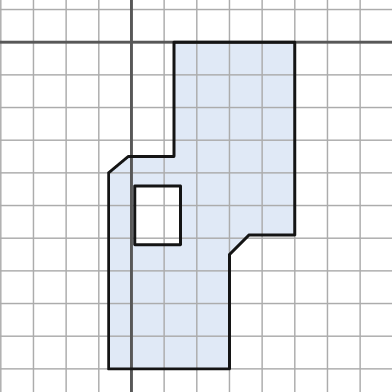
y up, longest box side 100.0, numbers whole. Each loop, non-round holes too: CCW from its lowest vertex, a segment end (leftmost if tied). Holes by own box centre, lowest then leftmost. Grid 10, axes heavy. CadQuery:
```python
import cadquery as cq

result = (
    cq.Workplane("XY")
    .moveTo(-7.0, -100.0)
    .lineTo(30.0, -100.0)
    .lineTo(30.0, -65.0)
    .lineTo(36.0, -59.0)
    .lineTo(50.0, -59.0)
    .lineTo(50.0, 0.0)
    .lineTo(13.0, 0.0)
    .lineTo(13.0, -35.0)
    .lineTo(-1.0, -35.0)
    .lineTo(-7.0, -40.0)
    .close()
    .moveTo(1.0, -62.0)
    .lineTo(15.0, -62.0)
    .lineTo(15.0, -44.0)
    .lineTo(1.0, -44.0)
    .close()
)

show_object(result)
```